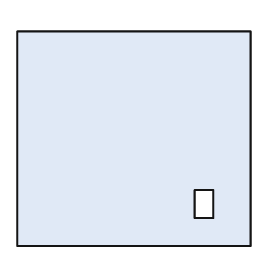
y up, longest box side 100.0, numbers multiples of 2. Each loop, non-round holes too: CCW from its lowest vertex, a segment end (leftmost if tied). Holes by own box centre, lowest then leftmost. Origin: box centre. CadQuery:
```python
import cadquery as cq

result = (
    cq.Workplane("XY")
    .moveTo(-50.0, -46.0)
    .lineTo(50.0, -46.0)
    .lineTo(50.0, 46.0)
    .lineTo(-50.0, 46.0)
    .close()
    .moveTo(26.0, -34.0)
    .lineTo(34.0, -34.0)
    .lineTo(34.0, -22.0)
    .lineTo(26.0, -22.0)
    .close()
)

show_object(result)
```